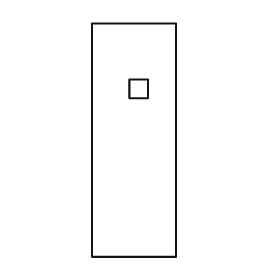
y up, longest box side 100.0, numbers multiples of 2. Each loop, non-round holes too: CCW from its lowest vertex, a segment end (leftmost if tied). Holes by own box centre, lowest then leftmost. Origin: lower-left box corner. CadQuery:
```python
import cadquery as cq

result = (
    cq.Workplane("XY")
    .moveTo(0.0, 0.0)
    .lineTo(36.0, 0.0)
    .lineTo(36.0, 100.0)
    .lineTo(0.0, 100.0)
    .close()
    .moveTo(16.0, 68.0)
    .lineTo(24.0, 68.0)
    .lineTo(24.0, 76.0)
    .lineTo(16.0, 76.0)
    .close()
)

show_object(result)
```